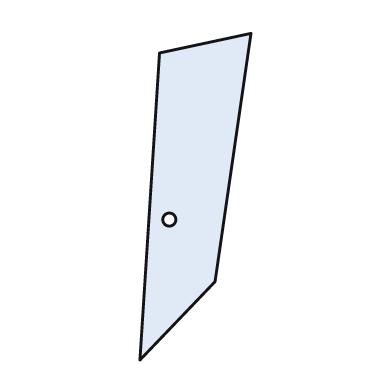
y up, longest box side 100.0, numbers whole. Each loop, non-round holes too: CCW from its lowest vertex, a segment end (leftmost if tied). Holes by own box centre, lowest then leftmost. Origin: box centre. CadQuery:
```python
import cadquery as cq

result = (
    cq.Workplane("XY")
    .moveTo(-17.0, -50.0)
    .lineTo(6.0, -26.0)
    .lineTo(17.0, 50.0)
    .lineTo(-11.0, 44.0)
    .close()
    .moveTo(-8.0, -7.0)
    .circle(2.0)
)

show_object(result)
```